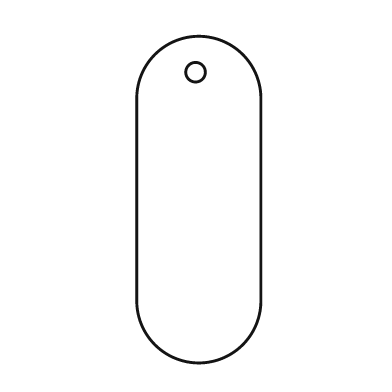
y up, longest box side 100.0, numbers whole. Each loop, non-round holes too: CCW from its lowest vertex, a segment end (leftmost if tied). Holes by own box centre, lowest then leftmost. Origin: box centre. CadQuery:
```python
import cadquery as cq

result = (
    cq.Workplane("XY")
    .moveTo(-19.0, -31.0)
    .threePointArc((0.0, -50.0), (19.0, -31.0))
    .lineTo(19.0, 31.0)
    .threePointArc((0.0, 50.0), (-19.0, 31.0))
    .close()
    .moveTo(-1.0, 39.0)
    .circle(3.0)
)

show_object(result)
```